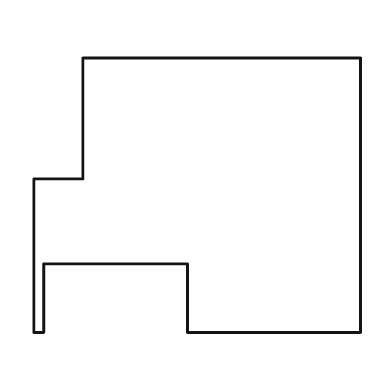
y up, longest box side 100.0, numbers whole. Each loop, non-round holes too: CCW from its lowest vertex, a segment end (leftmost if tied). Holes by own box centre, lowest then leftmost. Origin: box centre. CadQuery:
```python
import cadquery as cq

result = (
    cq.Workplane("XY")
    .moveTo(-50.0, -42.0)
    .lineTo(-47.0, -42.0)
    .lineTo(-47.0, -21.0)
    .lineTo(-3.0, -21.0)
    .lineTo(-3.0, -42.0)
    .lineTo(50.0, -42.0)
    .lineTo(50.0, 42.0)
    .lineTo(-35.0, 42.0)
    .lineTo(-35.0, 5.0)
    .lineTo(-50.0, 5.0)
    .close()
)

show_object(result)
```